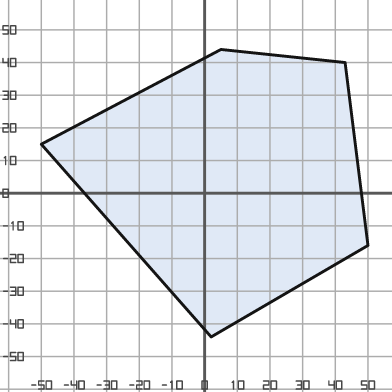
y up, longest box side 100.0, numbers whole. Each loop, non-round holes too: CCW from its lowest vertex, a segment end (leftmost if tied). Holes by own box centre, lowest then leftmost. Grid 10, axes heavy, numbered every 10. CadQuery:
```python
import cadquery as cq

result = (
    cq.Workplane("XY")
    .moveTo(2.0, -44.0)
    .lineTo(50.0, -16.0)
    .lineTo(43.0, 40.0)
    .lineTo(5.0, 44.0)
    .lineTo(-50.0, 15.0)
    .close()
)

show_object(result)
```